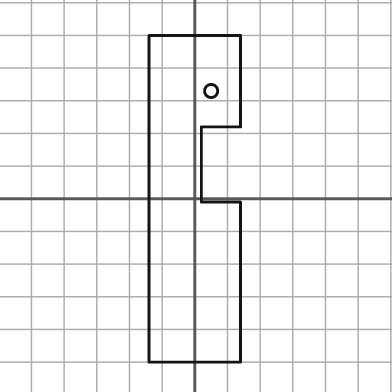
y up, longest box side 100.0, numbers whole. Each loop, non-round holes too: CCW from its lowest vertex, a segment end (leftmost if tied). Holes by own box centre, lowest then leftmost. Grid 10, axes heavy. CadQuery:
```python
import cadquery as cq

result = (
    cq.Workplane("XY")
    .moveTo(-14.0, -50.0)
    .lineTo(14.0, -50.0)
    .lineTo(14.0, -1.0)
    .lineTo(2.0, -1.0)
    .lineTo(2.0, 22.0)
    .lineTo(14.0, 22.0)
    .lineTo(14.0, 50.0)
    .lineTo(-14.0, 50.0)
    .close()
    .moveTo(5.0, 33.0)
    .circle(2.0)
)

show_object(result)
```